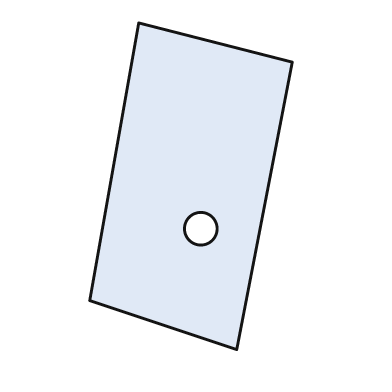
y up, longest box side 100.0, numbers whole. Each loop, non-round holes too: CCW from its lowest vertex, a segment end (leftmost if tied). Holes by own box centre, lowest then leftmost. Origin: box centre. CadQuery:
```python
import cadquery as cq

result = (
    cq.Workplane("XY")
    .moveTo(14.0, -50.0)
    .lineTo(31.0, 38.0)
    .lineTo(-16.0, 50.0)
    .lineTo(-31.0, -35.0)
    .close()
    .moveTo(3.0, -13.0)
    .circle(5.0)
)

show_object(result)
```